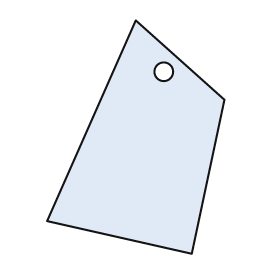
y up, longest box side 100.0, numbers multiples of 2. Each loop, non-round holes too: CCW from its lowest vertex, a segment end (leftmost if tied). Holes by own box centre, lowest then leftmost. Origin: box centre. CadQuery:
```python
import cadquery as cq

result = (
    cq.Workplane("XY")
    .moveTo(24.0, -50.0)
    .lineTo(38.0, 16.0)
    .lineTo(0.0, 50.0)
    .lineTo(-38.0, -36.0)
    .close()
    .moveTo(12.0, 28.0)
    .circle(4.0)
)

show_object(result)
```